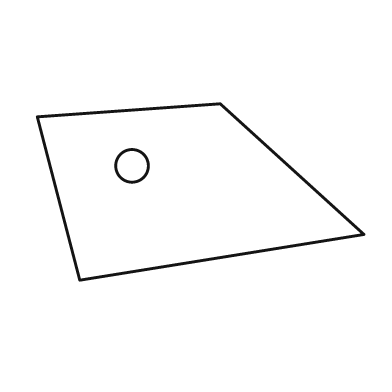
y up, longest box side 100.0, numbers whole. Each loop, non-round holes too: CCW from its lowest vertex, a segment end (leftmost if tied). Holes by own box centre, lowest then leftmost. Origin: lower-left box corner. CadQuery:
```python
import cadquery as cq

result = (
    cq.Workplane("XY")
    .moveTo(13.0, 0.0)
    .lineTo(100.0, 14.0)
    .lineTo(56.0, 54.0)
    .lineTo(0.0, 50.0)
    .close()
    .moveTo(29.0, 35.0)
    .circle(5.0)
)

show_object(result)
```